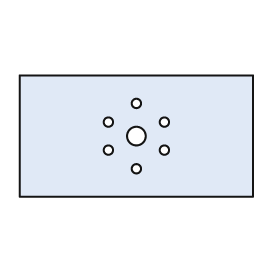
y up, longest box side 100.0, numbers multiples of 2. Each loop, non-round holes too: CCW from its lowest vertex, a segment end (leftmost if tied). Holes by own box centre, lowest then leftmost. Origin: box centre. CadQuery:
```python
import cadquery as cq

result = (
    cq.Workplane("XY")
    .moveTo(-50.0, -26.0)
    .lineTo(50.0, -26.0)
    .lineTo(50.0, 26.0)
    .lineTo(-50.0, 26.0)
    .close()
    .moveTo(0.0, -14.0)
    .circle(2.0)
    .moveTo(-12.0, -6.0)
    .circle(2.0)
    .moveTo(12.0, -6.0)
    .circle(2.0)
    .moveTo(0.0, 0.0)
    .circle(4.0)
    .moveTo(-12.0, 6.0)
    .circle(2.0)
    .moveTo(12.0, 6.0)
    .circle(2.0)
    .moveTo(0.0, 14.0)
    .circle(2.0)
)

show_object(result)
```